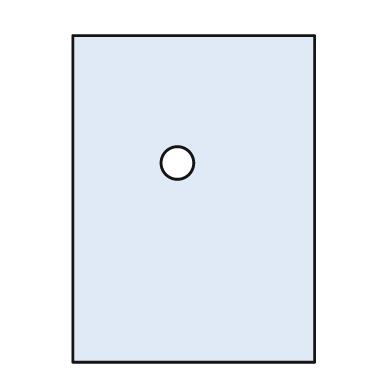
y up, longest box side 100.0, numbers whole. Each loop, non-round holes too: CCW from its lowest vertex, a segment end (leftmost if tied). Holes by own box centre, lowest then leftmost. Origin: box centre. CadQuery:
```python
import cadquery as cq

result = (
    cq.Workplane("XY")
    .moveTo(-37.0, -50.0)
    .lineTo(37.0, -50.0)
    .lineTo(37.0, 50.0)
    .lineTo(-37.0, 50.0)
    .close()
    .moveTo(-5.0, 11.0)
    .circle(5.0)
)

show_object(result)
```